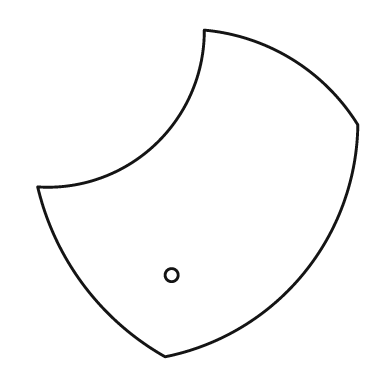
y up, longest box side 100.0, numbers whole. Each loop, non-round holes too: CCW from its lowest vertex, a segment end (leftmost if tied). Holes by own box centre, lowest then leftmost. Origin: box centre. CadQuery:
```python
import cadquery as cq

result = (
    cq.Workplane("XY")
    .moveTo(-10.0, -50.0)
    .threePointArc((32.0, -25.0), (49.0, 21.0))
    .threePointArc((29.0, 41.0), (2.0, 50.0))
    .threePointArc((-13.0, 15.0), (-49.0, 2.0))
    .threePointArc((-35.0, -28.0), (-10.0, -50.0))
    .close()
    .moveTo(-8.0, -25.0)
    .circle(2.0)
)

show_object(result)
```